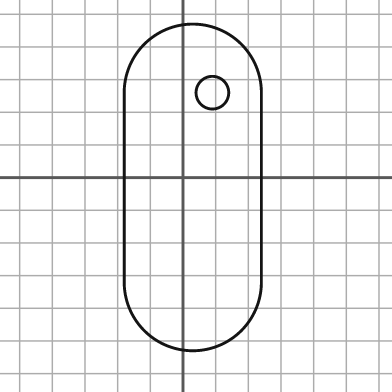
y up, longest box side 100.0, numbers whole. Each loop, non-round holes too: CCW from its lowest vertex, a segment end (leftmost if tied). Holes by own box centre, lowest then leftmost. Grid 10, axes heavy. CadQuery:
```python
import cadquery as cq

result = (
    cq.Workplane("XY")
    .moveTo(-18.0, -32.0)
    .threePointArc((3.0, -53.0), (24.0, -32.0))
    .lineTo(24.0, 26.0)
    .threePointArc((3.0, 47.0), (-18.0, 26.0))
    .close()
    .moveTo(9.0, 26.0)
    .circle(5.0)
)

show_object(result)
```